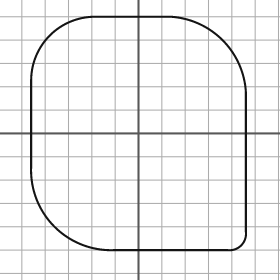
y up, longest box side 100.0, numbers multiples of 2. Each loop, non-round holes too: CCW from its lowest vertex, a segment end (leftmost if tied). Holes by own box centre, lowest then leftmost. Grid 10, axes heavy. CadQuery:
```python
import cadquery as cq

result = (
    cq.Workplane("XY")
    .moveTo(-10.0, -50.0)
    .lineTo(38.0, -50.0)
    .threePointArc((44.0, -48.0), (46.0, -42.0))
    .lineTo(46.0, 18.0)
    .threePointArc((36.0, 40.0), (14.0, 50.0))
    .lineTo(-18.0, 50.0)
    .threePointArc((-38.0, 42.0), (-46.0, 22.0))
    .lineTo(-46.0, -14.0)
    .threePointArc((-36.0, -40.0), (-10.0, -50.0))
    .close()
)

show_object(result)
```